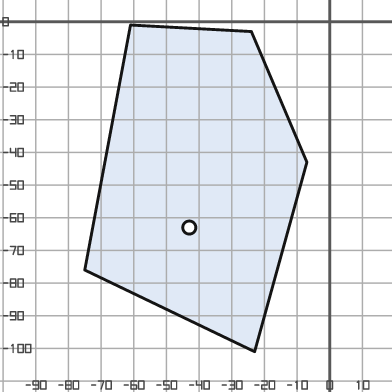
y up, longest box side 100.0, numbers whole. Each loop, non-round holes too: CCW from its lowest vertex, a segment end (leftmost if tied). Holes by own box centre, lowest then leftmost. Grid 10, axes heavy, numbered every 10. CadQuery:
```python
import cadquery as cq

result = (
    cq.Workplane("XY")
    .moveTo(-23.0, -101.0)
    .lineTo(-7.0, -43.0)
    .lineTo(-24.0, -3.0)
    .lineTo(-61.0, -1.0)
    .lineTo(-75.0, -76.0)
    .close()
    .moveTo(-43.0, -63.0)
    .circle(2.0)
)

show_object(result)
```